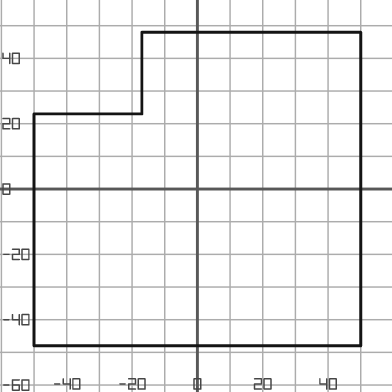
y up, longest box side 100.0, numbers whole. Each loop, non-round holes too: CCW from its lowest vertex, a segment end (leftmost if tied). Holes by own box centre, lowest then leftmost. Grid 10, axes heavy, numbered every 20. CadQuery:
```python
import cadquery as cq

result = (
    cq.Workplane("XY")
    .moveTo(-50.0, -48.0)
    .lineTo(50.0, -48.0)
    .lineTo(50.0, 48.0)
    .lineTo(-17.0, 48.0)
    .lineTo(-17.0, 23.0)
    .lineTo(-50.0, 23.0)
    .close()
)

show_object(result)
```